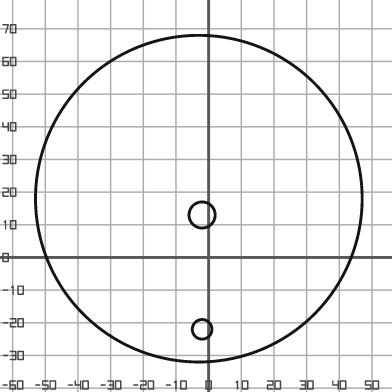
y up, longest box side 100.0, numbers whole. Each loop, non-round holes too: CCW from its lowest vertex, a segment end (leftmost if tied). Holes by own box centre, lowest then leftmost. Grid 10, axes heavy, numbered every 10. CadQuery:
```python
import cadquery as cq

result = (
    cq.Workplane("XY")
    .moveTo(-3.0, 18.0)
    .circle(50.0)
    .moveTo(-2.0, -22.0)
    .circle(3.0)
    .moveTo(-2.0, 13.0)
    .circle(4.0)
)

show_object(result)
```